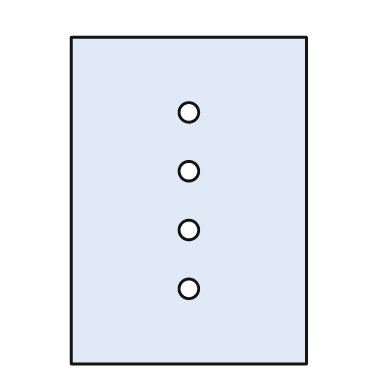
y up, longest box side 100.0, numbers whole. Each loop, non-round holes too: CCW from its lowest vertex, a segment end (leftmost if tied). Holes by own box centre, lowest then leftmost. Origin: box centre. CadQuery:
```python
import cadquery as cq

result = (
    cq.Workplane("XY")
    .moveTo(-36.0, -50.0)
    .lineTo(36.0, -50.0)
    .lineTo(36.0, 50.0)
    .lineTo(-36.0, 50.0)
    .close()
    .moveTo(0.0, -27.0)
    .circle(3.0)
    .moveTo(0.0, -9.0)
    .circle(3.0)
    .moveTo(0.0, 9.0)
    .circle(3.0)
    .moveTo(0.0, 27.0)
    .circle(3.0)
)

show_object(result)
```